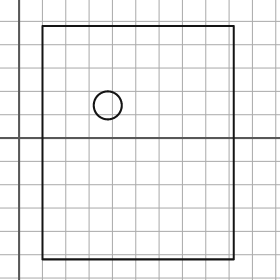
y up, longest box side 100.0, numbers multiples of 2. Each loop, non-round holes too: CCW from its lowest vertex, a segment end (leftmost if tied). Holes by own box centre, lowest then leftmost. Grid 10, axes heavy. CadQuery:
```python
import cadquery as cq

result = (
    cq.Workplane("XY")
    .moveTo(10.0, -52.0)
    .lineTo(92.0, -52.0)
    .lineTo(92.0, 48.0)
    .lineTo(10.0, 48.0)
    .close()
    .moveTo(38.0, 14.0)
    .circle(6.0)
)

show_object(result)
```